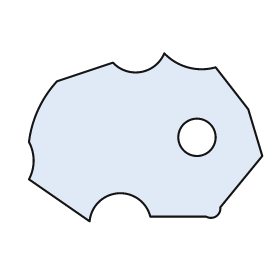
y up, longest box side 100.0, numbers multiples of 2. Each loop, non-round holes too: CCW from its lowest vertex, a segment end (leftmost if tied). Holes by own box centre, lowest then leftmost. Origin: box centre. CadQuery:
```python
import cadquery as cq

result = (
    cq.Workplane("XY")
    .moveTo(-24.0, -36.0)
    .threePointArc((-12.0, -24.0), (2.0, -34.0))
    .lineTo(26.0, -34.0)
    .threePointArc((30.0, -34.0), (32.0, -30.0))
    .lineTo(50.0, -8.0)
    .lineTo(44.0, 12.0)
    .lineTo(30.0, 30.0)
    .threePointArc((18.0, 30.0), (8.0, 36.0))
    .threePointArc((-2.0, 28.0), (-14.0, 32.0))
    .lineTo(-38.0, 24.0)
    .threePointArc((-46.0, 12.0), (-50.0, -2.0))
    .threePointArc((-48.0, -10.0), (-50.0, -18.0))
    .close()
    .moveTo(22.0, 0.0)
    .circle(8.0)
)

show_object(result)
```